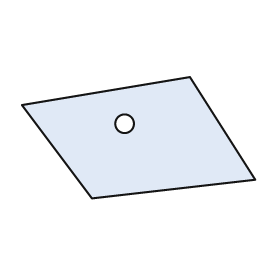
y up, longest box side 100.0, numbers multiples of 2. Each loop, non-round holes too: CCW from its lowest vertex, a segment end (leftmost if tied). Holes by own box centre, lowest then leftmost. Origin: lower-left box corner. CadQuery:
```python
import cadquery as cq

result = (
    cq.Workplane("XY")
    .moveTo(30.0, 0.0)
    .lineTo(100.0, 8.0)
    .lineTo(72.0, 52.0)
    .lineTo(0.0, 40.0)
    .close()
    .moveTo(44.0, 32.0)
    .circle(4.0)
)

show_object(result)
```